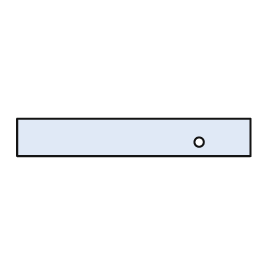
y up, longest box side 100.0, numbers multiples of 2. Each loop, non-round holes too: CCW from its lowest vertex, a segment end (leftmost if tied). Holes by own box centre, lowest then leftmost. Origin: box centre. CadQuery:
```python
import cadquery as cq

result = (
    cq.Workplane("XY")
    .moveTo(-50.0, -8.0)
    .lineTo(50.0, -8.0)
    .lineTo(50.0, 8.0)
    .lineTo(-50.0, 8.0)
    .close()
    .moveTo(28.0, -2.0)
    .circle(2.0)
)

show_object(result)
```